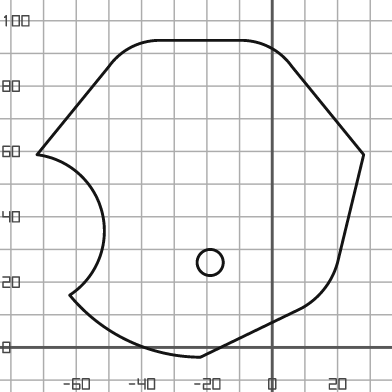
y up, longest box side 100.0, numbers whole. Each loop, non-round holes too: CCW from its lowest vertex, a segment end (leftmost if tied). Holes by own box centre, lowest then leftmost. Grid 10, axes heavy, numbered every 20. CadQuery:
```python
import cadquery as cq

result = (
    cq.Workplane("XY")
    .moveTo(-22.0, -3.0)
    .lineTo(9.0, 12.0)
    .threePointArc((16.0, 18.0), (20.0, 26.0))
    .lineTo(28.0, 59.0)
    .lineTo(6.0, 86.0)
    .threePointArc((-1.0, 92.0), (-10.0, 94.0))
    .lineTo(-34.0, 94.0)
    .threePointArc((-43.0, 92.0), (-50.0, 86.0))
    .lineTo(-72.0, 59.0)
    .threePointArc((-52.0, 41.0), (-62.0, 16.0))
    .threePointArc((-44.0, 2.0), (-22.0, -3.0))
    .close()
    .moveTo(-19.0, 26.0)
    .circle(4.0)
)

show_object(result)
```